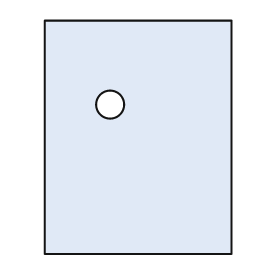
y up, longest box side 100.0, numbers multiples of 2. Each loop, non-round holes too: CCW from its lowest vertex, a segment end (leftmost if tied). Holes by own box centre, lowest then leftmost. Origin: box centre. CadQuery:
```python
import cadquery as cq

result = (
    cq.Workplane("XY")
    .moveTo(-40.0, -50.0)
    .lineTo(40.0, -50.0)
    .lineTo(40.0, 50.0)
    .lineTo(-40.0, 50.0)
    .close()
    .moveTo(-12.0, 14.0)
    .circle(6.0)
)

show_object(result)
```